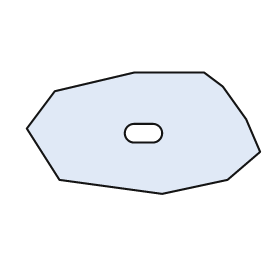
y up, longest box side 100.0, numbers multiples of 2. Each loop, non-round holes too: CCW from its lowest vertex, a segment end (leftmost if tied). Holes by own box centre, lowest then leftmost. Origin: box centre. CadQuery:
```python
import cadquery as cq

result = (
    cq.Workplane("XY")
    .moveTo(8.0, -26.0)
    .lineTo(36.0, -20.0)
    .lineTo(50.0, -8.0)
    .lineTo(44.0, 6.0)
    .lineTo(34.0, 20.0)
    .lineTo(26.0, 26.0)
    .lineTo(-4.0, 26.0)
    .lineTo(-38.0, 18.0)
    .lineTo(-50.0, 2.0)
    .lineTo(-36.0, -20.0)
    .close()
    .moveTo(-4.0, -4.0)
    .lineTo(4.0, -4.0)
    .threePointArc((8.0, 0.0), (4.0, 4.0))
    .lineTo(-4.0, 4.0)
    .threePointArc((-8.0, 0.0), (-4.0, -4.0))
    .close()
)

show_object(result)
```